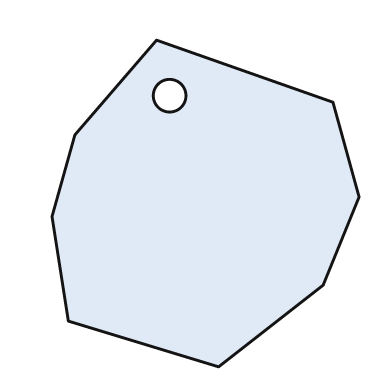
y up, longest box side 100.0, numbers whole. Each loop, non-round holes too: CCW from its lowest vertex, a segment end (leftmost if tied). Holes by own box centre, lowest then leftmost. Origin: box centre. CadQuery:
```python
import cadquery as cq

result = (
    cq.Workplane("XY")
    .moveTo(4.0, -50.0)
    .lineTo(36.0, -25.0)
    .lineTo(47.0, 2.0)
    .lineTo(39.0, 31.0)
    .lineTo(-15.0, 50.0)
    .lineTo(-40.0, 21.0)
    .lineTo(-47.0, -4.0)
    .lineTo(-42.0, -36.0)
    .close()
    .moveTo(-11.0, 33.0)
    .circle(5.0)
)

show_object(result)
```